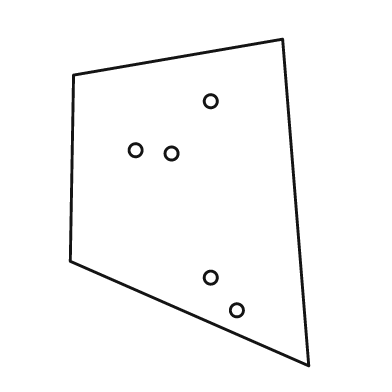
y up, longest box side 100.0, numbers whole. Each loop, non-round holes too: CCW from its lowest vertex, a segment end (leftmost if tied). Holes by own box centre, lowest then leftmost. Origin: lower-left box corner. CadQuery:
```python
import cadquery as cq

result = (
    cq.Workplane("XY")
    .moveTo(73.0, 0.0)
    .lineTo(65.0, 100.0)
    .lineTo(1.0, 89.0)
    .lineTo(0.0, 32.0)
    .close()
    .moveTo(51.0, 17.0)
    .circle(2.0)
    .moveTo(43.0, 27.0)
    .circle(2.0)
    .moveTo(31.0, 65.0)
    .circle(2.0)
    .moveTo(20.0, 66.0)
    .circle(2.0)
    .moveTo(43.0, 81.0)
    .circle(2.0)
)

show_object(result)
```